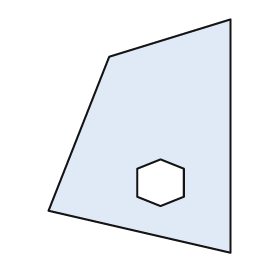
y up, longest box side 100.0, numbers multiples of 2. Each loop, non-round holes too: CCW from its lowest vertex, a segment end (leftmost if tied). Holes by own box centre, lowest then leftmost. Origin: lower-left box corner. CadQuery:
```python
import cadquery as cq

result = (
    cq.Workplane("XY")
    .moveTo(78.0, 0.0)
    .lineTo(78.0, 100.0)
    .lineTo(26.0, 84.0)
    .lineTo(0.0, 18.0)
    .close()
    .moveTo(48.0, 20.0)
    .lineTo(58.0, 24.0)
    .lineTo(58.0, 36.0)
    .lineTo(48.0, 40.0)
    .lineTo(38.0, 36.0)
    .lineTo(38.0, 24.0)
    .close()
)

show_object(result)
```